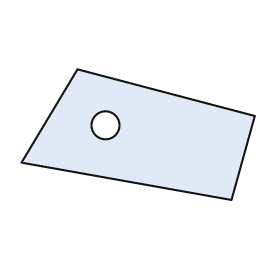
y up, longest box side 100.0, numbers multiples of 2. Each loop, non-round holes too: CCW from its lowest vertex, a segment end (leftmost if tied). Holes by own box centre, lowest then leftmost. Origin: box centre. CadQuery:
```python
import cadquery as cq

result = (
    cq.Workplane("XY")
    .moveTo(40.0, -28.0)
    .lineTo(50.0, 8.0)
    .lineTo(-26.0, 28.0)
    .lineTo(-50.0, -12.0)
    .close()
    .moveTo(-14.0, 4.0)
    .circle(6.0)
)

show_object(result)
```